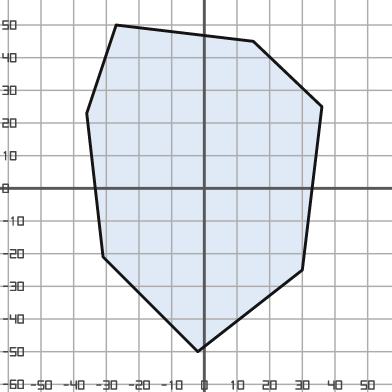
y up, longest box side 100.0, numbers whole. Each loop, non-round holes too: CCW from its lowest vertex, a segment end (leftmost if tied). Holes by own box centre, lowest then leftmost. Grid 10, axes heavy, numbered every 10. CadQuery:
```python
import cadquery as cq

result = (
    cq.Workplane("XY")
    .moveTo(-2.0, -50.0)
    .lineTo(30.0, -25.0)
    .lineTo(36.0, 25.0)
    .lineTo(15.0, 45.0)
    .lineTo(-27.0, 50.0)
    .lineTo(-36.0, 23.0)
    .lineTo(-31.0, -21.0)
    .close()
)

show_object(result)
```